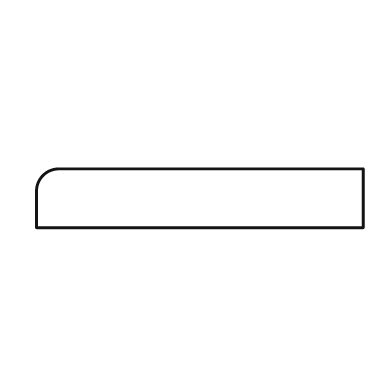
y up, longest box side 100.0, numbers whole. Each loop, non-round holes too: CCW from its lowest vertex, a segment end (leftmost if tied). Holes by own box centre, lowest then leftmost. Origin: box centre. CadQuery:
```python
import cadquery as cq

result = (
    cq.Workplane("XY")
    .moveTo(-50.0, -9.0)
    .lineTo(50.0, -9.0)
    .lineTo(50.0, 9.0)
    .lineTo(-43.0, 9.0)
    .threePointArc((-48.0, 7.0), (-50.0, 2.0))
    .close()
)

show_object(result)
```